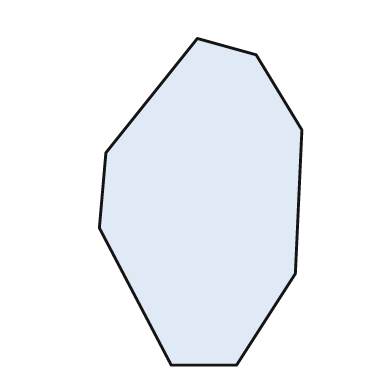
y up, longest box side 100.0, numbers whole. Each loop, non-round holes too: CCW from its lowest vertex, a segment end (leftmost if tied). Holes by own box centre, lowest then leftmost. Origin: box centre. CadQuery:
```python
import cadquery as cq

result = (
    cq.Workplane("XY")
    .moveTo(-9.0, -50.0)
    .lineTo(11.0, -50.0)
    .lineTo(29.0, -22.0)
    .lineTo(31.0, 22.0)
    .lineTo(17.0, 45.0)
    .lineTo(-1.0, 50.0)
    .lineTo(-29.0, 15.0)
    .lineTo(-31.0, -8.0)
    .close()
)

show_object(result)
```